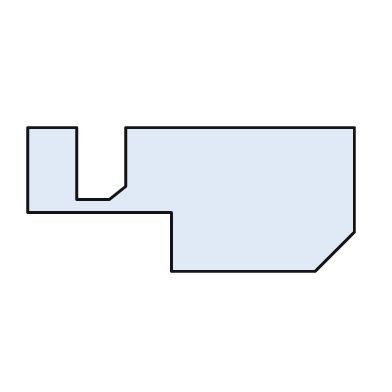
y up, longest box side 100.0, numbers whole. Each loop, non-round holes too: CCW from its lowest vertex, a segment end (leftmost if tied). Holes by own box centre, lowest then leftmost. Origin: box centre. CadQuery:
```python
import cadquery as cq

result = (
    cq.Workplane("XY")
    .moveTo(-6.0, -22.0)
    .lineTo(38.0, -22.0)
    .lineTo(50.0, -10.0)
    .lineTo(50.0, 22.0)
    .lineTo(-20.0, 22.0)
    .lineTo(-20.0, 4.0)
    .lineTo(-25.0, 0.0)
    .lineTo(-35.0, 0.0)
    .lineTo(-35.0, 22.0)
    .lineTo(-50.0, 22.0)
    .lineTo(-50.0, -4.0)
    .lineTo(-6.0, -4.0)
    .close()
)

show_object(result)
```